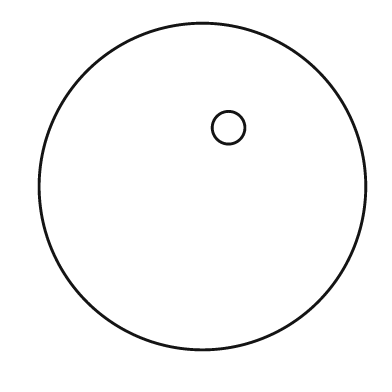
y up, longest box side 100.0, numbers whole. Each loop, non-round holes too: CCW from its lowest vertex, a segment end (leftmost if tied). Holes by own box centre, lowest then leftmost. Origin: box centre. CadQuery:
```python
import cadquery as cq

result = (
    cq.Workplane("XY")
    .moveTo(0.0, 0.0)
    .circle(50.0)
    .moveTo(8.0, 18.0)
    .circle(5.0)
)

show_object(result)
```